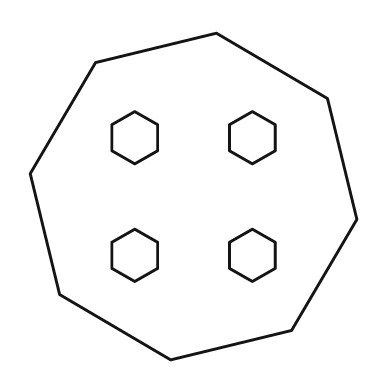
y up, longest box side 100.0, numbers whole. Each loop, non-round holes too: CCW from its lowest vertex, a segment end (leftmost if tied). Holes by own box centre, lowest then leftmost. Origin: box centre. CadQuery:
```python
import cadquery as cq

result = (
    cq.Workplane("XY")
    .moveTo(-7.0, -50.0)
    .lineTo(30.0, -41.0)
    .lineTo(50.0, -7.0)
    .lineTo(41.0, 30.0)
    .lineTo(7.0, 50.0)
    .lineTo(-30.0, 41.0)
    .lineTo(-50.0, 7.0)
    .lineTo(-41.0, -30.0)
    .close()
    .moveTo(-18.0, -26.0)
    .lineTo(-11.0, -22.0)
    .lineTo(-11.0, -14.0)
    .lineTo(-18.0, -10.0)
    .lineTo(-25.0, -14.0)
    .lineTo(-25.0, -22.0)
    .close()
    .moveTo(18.0, -26.0)
    .lineTo(25.0, -22.0)
    .lineTo(25.0, -14.0)
    .lineTo(18.0, -10.0)
    .lineTo(11.0, -14.0)
    .lineTo(11.0, -22.0)
    .close()
    .moveTo(-18.0, 10.0)
    .lineTo(-11.0, 14.0)
    .lineTo(-11.0, 22.0)
    .lineTo(-18.0, 26.0)
    .lineTo(-25.0, 22.0)
    .lineTo(-25.0, 14.0)
    .close()
    .moveTo(18.0, 10.0)
    .lineTo(25.0, 14.0)
    .lineTo(25.0, 22.0)
    .lineTo(18.0, 26.0)
    .lineTo(11.0, 22.0)
    .lineTo(11.0, 14.0)
    .close()
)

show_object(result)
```